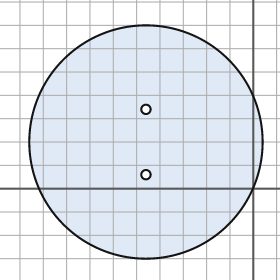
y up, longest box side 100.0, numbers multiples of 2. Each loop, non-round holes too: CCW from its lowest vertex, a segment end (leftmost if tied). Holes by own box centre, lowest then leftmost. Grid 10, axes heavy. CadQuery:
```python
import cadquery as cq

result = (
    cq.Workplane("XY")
    .moveTo(-46.0, 20.0)
    .circle(50.0)
    .moveTo(-46.0, 6.0)
    .circle(2.0)
    .moveTo(-46.0, 34.0)
    .circle(2.0)
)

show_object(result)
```